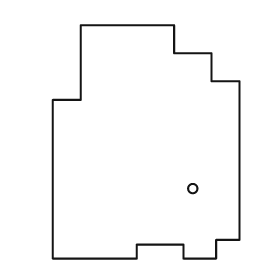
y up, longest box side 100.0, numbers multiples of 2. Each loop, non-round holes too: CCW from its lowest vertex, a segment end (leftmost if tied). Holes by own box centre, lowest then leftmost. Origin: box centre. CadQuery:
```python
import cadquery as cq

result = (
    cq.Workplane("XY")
    .moveTo(-40.0, -50.0)
    .lineTo(-4.0, -50.0)
    .lineTo(-4.0, -44.0)
    .lineTo(16.0, -44.0)
    .lineTo(16.0, -50.0)
    .lineTo(30.0, -50.0)
    .lineTo(30.0, -42.0)
    .lineTo(40.0, -42.0)
    .lineTo(40.0, 26.0)
    .lineTo(28.0, 26.0)
    .lineTo(28.0, 38.0)
    .lineTo(12.0, 38.0)
    .lineTo(12.0, 50.0)
    .lineTo(-28.0, 50.0)
    .lineTo(-28.0, 18.0)
    .lineTo(-40.0, 18.0)
    .close()
    .moveTo(20.0, -20.0)
    .circle(2.0)
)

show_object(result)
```